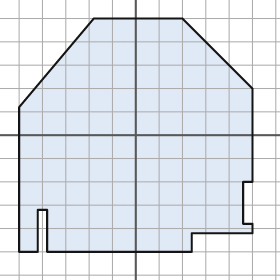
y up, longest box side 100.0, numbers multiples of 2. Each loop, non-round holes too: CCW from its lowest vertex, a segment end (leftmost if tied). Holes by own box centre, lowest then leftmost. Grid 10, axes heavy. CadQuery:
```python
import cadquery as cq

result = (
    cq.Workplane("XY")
    .moveTo(-50.0, -50.0)
    .lineTo(-42.0, -50.0)
    .lineTo(-42.0, -32.0)
    .lineTo(-38.0, -32.0)
    .lineTo(-38.0, -50.0)
    .lineTo(24.0, -50.0)
    .lineTo(24.0, -42.0)
    .lineTo(50.0, -42.0)
    .lineTo(50.0, -38.0)
    .lineTo(46.0, -38.0)
    .lineTo(46.0, -20.0)
    .lineTo(50.0, -20.0)
    .lineTo(50.0, 20.0)
    .lineTo(20.0, 50.0)
    .lineTo(-18.0, 50.0)
    .lineTo(-50.0, 12.0)
    .close()
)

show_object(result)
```